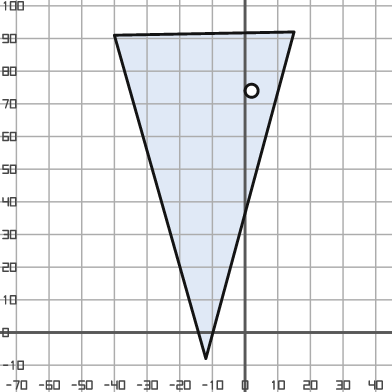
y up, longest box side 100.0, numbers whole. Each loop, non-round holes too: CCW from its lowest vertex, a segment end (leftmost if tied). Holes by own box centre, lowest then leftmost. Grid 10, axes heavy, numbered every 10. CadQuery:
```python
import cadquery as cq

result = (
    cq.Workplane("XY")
    .moveTo(-12.0, -8.0)
    .lineTo(15.0, 92.0)
    .lineTo(-40.0, 91.0)
    .close()
    .moveTo(2.0, 74.0)
    .circle(2.0)
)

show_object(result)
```